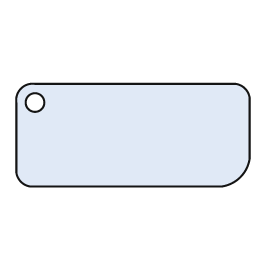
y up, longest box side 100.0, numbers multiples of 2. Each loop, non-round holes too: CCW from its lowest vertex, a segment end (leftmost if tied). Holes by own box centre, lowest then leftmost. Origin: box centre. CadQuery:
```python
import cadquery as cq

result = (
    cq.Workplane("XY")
    .moveTo(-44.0, -22.0)
    .lineTo(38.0, -22.0)
    .threePointArc((46.0, -18.0), (50.0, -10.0))
    .lineTo(50.0, 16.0)
    .threePointArc((48.0, 20.0), (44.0, 22.0))
    .lineTo(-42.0, 22.0)
    .threePointArc((-48.0, 20.0), (-50.0, 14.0))
    .lineTo(-50.0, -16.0)
    .threePointArc((-48.0, -20.0), (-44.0, -22.0))
    .close()
    .moveTo(-42.0, 14.0)
    .circle(4.0)
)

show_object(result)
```